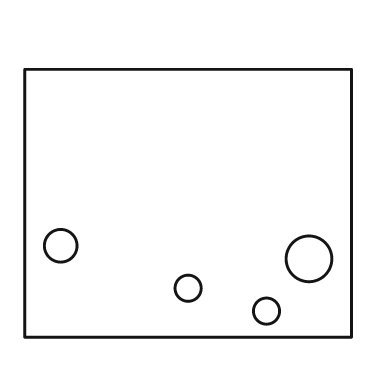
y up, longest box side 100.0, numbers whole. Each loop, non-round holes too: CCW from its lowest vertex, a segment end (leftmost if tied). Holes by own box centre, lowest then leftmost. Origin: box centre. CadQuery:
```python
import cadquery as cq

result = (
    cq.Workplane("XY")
    .moveTo(-50.0, -41.0)
    .lineTo(50.0, -41.0)
    .lineTo(50.0, 41.0)
    .lineTo(-50.0, 41.0)
    .close()
    .moveTo(24.0, -33.0)
    .circle(4.0)
    .moveTo(0.0, -26.0)
    .circle(4.0)
    .moveTo(37.0, -17.0)
    .circle(7.0)
    .moveTo(-39.0, -13.0)
    .circle(5.0)
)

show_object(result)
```